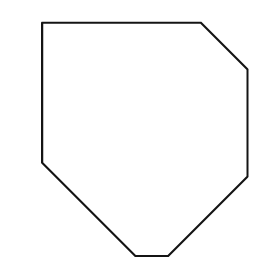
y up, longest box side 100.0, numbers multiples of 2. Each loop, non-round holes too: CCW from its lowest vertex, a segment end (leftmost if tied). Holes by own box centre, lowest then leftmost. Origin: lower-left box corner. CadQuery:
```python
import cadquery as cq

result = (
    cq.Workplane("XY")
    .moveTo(40.0, 0.0)
    .lineTo(54.0, 0.0)
    .lineTo(88.0, 34.0)
    .lineTo(88.0, 80.0)
    .lineTo(68.0, 100.0)
    .lineTo(0.0, 100.0)
    .lineTo(0.0, 40.0)
    .close()
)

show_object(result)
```